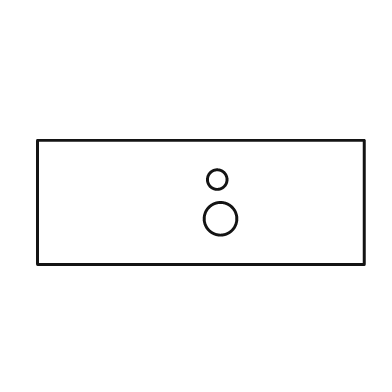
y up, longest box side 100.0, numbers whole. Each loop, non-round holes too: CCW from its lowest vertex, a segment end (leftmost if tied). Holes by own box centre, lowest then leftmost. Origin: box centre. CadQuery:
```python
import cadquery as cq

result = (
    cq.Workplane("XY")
    .moveTo(-50.0, -19.0)
    .lineTo(50.0, -19.0)
    .lineTo(50.0, 19.0)
    .lineTo(-50.0, 19.0)
    .close()
    .moveTo(6.0, -5.0)
    .circle(5.0)
    .moveTo(5.0, 7.0)
    .circle(3.0)
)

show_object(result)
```